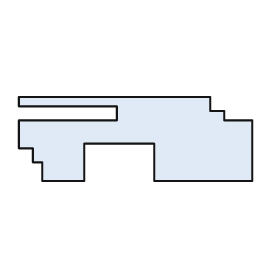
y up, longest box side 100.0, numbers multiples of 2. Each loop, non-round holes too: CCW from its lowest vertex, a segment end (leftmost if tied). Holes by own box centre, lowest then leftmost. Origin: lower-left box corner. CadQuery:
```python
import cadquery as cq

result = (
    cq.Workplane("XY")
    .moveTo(10.0, 0.0)
    .lineTo(28.0, 0.0)
    .lineTo(28.0, 16.0)
    .lineTo(58.0, 16.0)
    .lineTo(58.0, 0.0)
    .lineTo(100.0, 0.0)
    .lineTo(100.0, 26.0)
    .lineTo(88.0, 26.0)
    .lineTo(88.0, 30.0)
    .lineTo(82.0, 30.0)
    .lineTo(82.0, 36.0)
    .lineTo(0.0, 36.0)
    .lineTo(0.0, 32.0)
    .lineTo(42.0, 32.0)
    .lineTo(42.0, 26.0)
    .lineTo(0.0, 26.0)
    .lineTo(0.0, 14.0)
    .lineTo(6.0, 14.0)
    .lineTo(6.0, 8.0)
    .lineTo(10.0, 8.0)
    .close()
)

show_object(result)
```